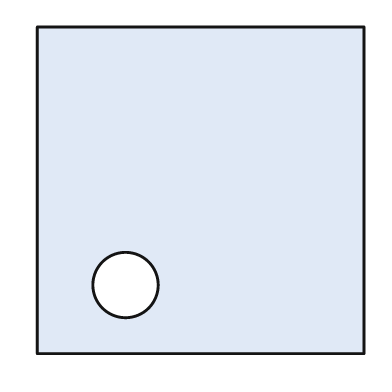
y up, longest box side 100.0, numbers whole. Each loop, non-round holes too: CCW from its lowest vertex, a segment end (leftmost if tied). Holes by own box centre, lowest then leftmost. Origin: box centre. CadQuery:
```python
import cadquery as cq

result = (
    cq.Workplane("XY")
    .moveTo(-50.0, -50.0)
    .lineTo(50.0, -50.0)
    .lineTo(50.0, 50.0)
    .lineTo(-50.0, 50.0)
    .close()
    .moveTo(-23.0, -29.0)
    .circle(10.0)
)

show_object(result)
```